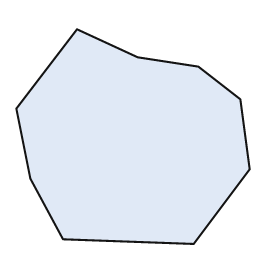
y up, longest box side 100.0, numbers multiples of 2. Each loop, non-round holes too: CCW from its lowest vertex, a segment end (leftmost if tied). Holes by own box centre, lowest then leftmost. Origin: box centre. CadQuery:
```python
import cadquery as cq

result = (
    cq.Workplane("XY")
    .moveTo(26.0, -46.0)
    .lineTo(50.0, -14.0)
    .lineTo(46.0, 16.0)
    .lineTo(28.0, 30.0)
    .lineTo(2.0, 34.0)
    .lineTo(-24.0, 46.0)
    .lineTo(-50.0, 12.0)
    .lineTo(-44.0, -18.0)
    .lineTo(-30.0, -44.0)
    .close()
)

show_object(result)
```